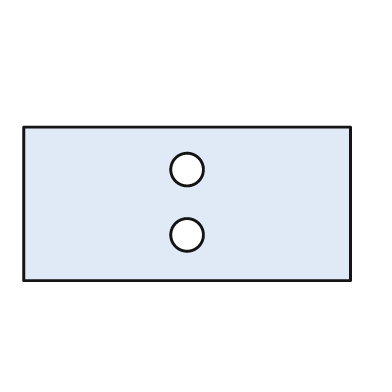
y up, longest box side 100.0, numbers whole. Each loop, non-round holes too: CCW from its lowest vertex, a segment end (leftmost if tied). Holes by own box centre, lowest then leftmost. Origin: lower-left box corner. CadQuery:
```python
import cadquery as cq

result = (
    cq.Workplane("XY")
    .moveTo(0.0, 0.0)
    .lineTo(100.0, 0.0)
    .lineTo(100.0, 47.0)
    .lineTo(0.0, 47.0)
    .close()
    .moveTo(50.0, 14.0)
    .circle(5.0)
    .moveTo(50.0, 34.0)
    .circle(5.0)
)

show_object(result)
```